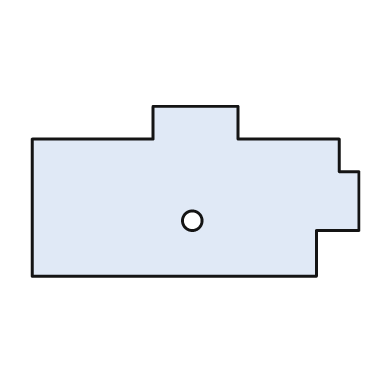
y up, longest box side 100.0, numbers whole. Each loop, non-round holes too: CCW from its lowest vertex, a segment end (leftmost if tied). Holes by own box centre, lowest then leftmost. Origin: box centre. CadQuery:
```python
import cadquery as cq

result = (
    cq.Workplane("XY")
    .moveTo(-50.0, -26.0)
    .lineTo(37.0, -26.0)
    .lineTo(37.0, -12.0)
    .lineTo(50.0, -12.0)
    .lineTo(50.0, 6.0)
    .lineTo(44.0, 6.0)
    .lineTo(44.0, 16.0)
    .lineTo(13.0, 16.0)
    .lineTo(13.0, 26.0)
    .lineTo(-13.0, 26.0)
    .lineTo(-13.0, 16.0)
    .lineTo(-50.0, 16.0)
    .close()
    .moveTo(-1.0, -9.0)
    .circle(3.0)
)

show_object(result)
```